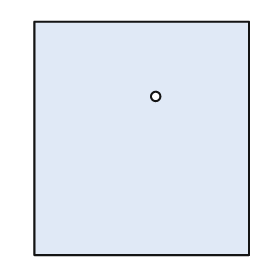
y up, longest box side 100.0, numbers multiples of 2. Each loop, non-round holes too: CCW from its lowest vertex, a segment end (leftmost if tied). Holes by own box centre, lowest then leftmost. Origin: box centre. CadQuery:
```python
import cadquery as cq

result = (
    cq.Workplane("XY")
    .moveTo(-46.0, -50.0)
    .lineTo(46.0, -50.0)
    .lineTo(46.0, 50.0)
    .lineTo(-46.0, 50.0)
    .close()
    .moveTo(6.0, 18.0)
    .circle(2.0)
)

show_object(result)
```